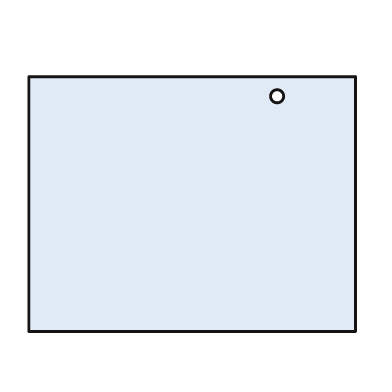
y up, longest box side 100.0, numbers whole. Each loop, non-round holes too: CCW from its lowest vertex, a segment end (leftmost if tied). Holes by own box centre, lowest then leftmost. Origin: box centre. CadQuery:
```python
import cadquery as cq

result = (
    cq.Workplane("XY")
    .moveTo(-50.0, -39.0)
    .lineTo(50.0, -39.0)
    .lineTo(50.0, 39.0)
    .lineTo(-50.0, 39.0)
    .close()
    .moveTo(26.0, 33.0)
    .circle(2.0)
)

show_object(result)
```